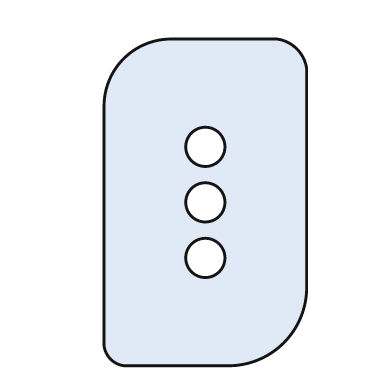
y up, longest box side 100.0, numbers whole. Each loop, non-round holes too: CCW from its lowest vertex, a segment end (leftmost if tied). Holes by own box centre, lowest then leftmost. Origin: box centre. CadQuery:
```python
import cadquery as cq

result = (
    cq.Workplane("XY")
    .moveTo(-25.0, -50.0)
    .lineTo(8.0, -50.0)
    .threePointArc((24.0, -43.0), (31.0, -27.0))
    .lineTo(31.0, 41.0)
    .threePointArc((28.0, 47.0), (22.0, 50.0))
    .lineTo(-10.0, 50.0)
    .threePointArc((-25.0, 44.0), (-31.0, 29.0))
    .lineTo(-31.0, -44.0)
    .threePointArc((-29.0, -48.0), (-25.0, -50.0))
    .close()
    .moveTo(0.0, -17.0)
    .circle(6.0)
    .moveTo(0.0, 0.0)
    .circle(6.0)
    .moveTo(0.0, 17.0)
    .circle(6.0)
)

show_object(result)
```